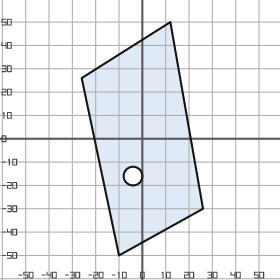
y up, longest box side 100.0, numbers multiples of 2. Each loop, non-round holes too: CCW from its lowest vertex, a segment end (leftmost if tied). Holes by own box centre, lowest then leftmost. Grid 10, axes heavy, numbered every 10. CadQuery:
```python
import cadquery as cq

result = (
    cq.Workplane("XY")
    .moveTo(-10.0, -50.0)
    .lineTo(26.0, -30.0)
    .lineTo(12.0, 50.0)
    .lineTo(-26.0, 26.0)
    .close()
    .moveTo(-4.0, -16.0)
    .circle(4.0)
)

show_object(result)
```